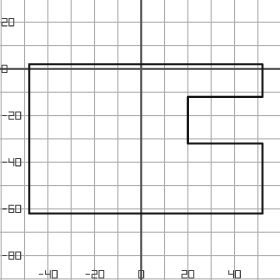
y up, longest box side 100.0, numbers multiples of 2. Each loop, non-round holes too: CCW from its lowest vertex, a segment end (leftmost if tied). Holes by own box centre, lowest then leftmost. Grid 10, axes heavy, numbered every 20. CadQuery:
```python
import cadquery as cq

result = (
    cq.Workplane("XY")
    .moveTo(-48.0, -62.0)
    .lineTo(52.0, -62.0)
    .lineTo(52.0, -32.0)
    .lineTo(20.0, -32.0)
    .lineTo(20.0, -12.0)
    .lineTo(52.0, -12.0)
    .lineTo(52.0, 2.0)
    .lineTo(-48.0, 2.0)
    .close()
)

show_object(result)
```